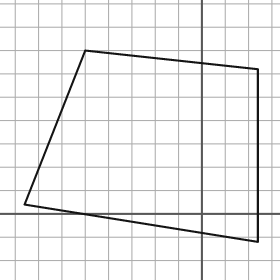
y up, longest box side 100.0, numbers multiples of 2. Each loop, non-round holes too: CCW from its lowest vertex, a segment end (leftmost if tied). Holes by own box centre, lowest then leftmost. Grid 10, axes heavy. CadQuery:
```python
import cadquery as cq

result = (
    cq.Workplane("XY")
    .moveTo(24.0, -12.0)
    .lineTo(24.0, 62.0)
    .lineTo(-50.0, 70.0)
    .lineTo(-76.0, 4.0)
    .close()
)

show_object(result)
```